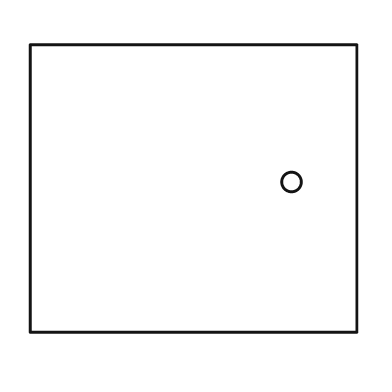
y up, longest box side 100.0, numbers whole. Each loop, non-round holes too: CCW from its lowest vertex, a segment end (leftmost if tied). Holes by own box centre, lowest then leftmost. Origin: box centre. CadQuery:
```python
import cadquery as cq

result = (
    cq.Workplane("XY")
    .moveTo(-50.0, -44.0)
    .lineTo(50.0, -44.0)
    .lineTo(50.0, 44.0)
    .lineTo(-50.0, 44.0)
    .close()
    .moveTo(30.0, 2.0)
    .circle(3.0)
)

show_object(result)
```